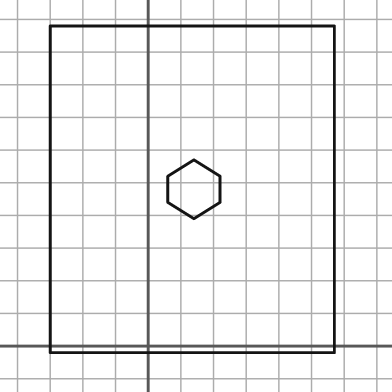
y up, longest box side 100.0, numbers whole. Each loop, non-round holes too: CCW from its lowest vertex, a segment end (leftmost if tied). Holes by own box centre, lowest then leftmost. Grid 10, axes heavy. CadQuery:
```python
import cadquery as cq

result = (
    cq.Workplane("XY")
    .moveTo(-30.0, -2.0)
    .lineTo(57.0, -2.0)
    .lineTo(57.0, 98.0)
    .lineTo(-30.0, 98.0)
    .close()
    .moveTo(14.0, 39.0)
    .lineTo(22.0, 44.0)
    .lineTo(22.0, 52.0)
    .lineTo(14.0, 57.0)
    .lineTo(6.0, 52.0)
    .lineTo(6.0, 44.0)
    .close()
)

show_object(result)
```